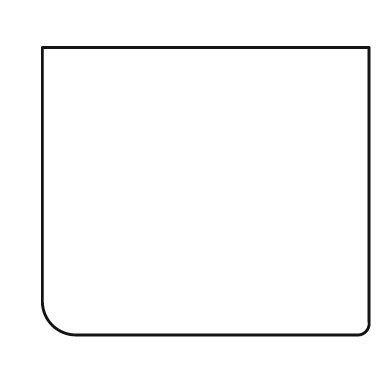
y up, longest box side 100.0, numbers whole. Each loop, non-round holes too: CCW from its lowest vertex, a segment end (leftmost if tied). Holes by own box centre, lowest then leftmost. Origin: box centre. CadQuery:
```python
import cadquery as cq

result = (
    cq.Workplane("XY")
    .moveTo(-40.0, -44.0)
    .lineTo(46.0, -44.0)
    .threePointArc((49.0, -43.0), (50.0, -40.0))
    .lineTo(50.0, 44.0)
    .lineTo(-50.0, 44.0)
    .lineTo(-50.0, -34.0)
    .threePointArc((-47.0, -41.0), (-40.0, -44.0))
    .close()
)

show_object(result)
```